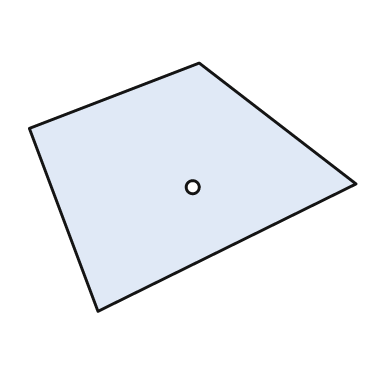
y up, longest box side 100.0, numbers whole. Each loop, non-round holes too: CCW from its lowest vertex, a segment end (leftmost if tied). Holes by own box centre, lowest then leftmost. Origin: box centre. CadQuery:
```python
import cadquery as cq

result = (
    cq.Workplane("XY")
    .moveTo(-29.0, -38.0)
    .lineTo(50.0, 1.0)
    .lineTo(2.0, 38.0)
    .lineTo(-50.0, 18.0)
    .close()
    .moveTo(0.0, 0.0)
    .circle(2.0)
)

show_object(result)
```